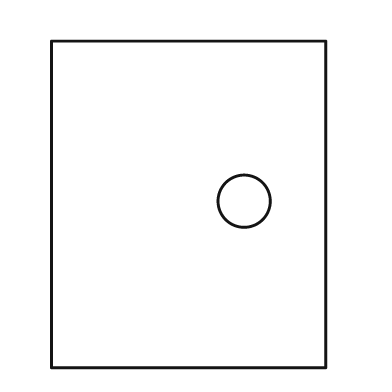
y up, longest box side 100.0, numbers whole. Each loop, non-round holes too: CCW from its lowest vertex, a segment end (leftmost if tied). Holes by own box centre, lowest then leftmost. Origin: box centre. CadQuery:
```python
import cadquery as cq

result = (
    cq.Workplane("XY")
    .moveTo(-42.0, -50.0)
    .lineTo(42.0, -50.0)
    .lineTo(42.0, 50.0)
    .lineTo(-42.0, 50.0)
    .close()
    .moveTo(17.0, 1.0)
    .circle(8.0)
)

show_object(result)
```